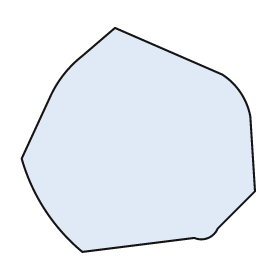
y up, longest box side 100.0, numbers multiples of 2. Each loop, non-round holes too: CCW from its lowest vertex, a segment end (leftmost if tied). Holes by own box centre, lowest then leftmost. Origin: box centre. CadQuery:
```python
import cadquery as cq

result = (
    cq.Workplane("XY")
    .moveTo(-24.0, -48.0)
    .lineTo(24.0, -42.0)
    .threePointArc((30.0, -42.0), (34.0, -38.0))
    .lineTo(50.0, -22.0)
    .lineTo(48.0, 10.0)
    .threePointArc((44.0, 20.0), (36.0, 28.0))
    .lineTo(-10.0, 48.0)
    .lineTo(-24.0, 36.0)
    .threePointArc((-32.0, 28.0), (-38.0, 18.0))
    .lineTo(-50.0, -8.0)
    .threePointArc((-40.0, -30.0), (-24.0, -48.0))
    .close()
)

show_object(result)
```